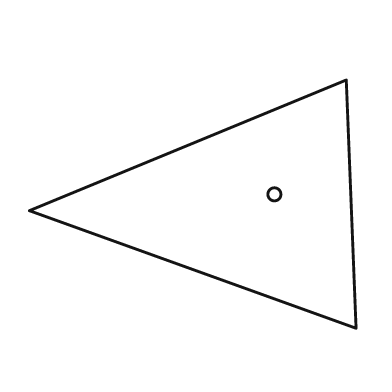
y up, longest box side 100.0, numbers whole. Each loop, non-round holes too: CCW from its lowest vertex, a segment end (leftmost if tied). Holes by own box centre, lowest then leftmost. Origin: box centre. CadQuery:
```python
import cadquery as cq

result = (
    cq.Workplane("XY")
    .moveTo(50.0, -38.0)
    .lineTo(47.0, 38.0)
    .lineTo(-50.0, -2.0)
    .close()
    .moveTo(25.0, 3.0)
    .circle(2.0)
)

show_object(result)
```